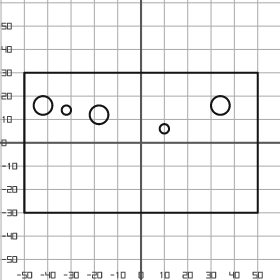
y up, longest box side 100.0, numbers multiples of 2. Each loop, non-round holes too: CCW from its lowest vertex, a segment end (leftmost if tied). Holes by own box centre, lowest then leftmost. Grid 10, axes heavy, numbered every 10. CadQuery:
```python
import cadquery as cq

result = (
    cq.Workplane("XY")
    .moveTo(-50.0, -30.0)
    .lineTo(50.0, -30.0)
    .lineTo(50.0, 30.0)
    .lineTo(-50.0, 30.0)
    .close()
    .moveTo(10.0, 6.0)
    .circle(2.0)
    .moveTo(-18.0, 12.0)
    .circle(4.0)
    .moveTo(-32.0, 14.0)
    .circle(2.0)
    .moveTo(-42.0, 16.0)
    .circle(4.0)
    .moveTo(34.0, 16.0)
    .circle(4.0)
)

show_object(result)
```